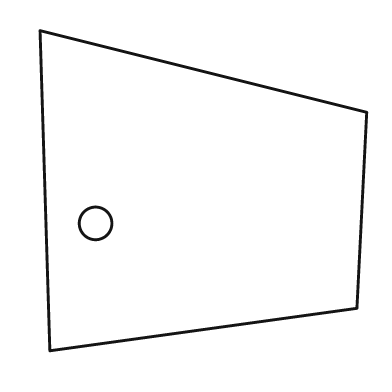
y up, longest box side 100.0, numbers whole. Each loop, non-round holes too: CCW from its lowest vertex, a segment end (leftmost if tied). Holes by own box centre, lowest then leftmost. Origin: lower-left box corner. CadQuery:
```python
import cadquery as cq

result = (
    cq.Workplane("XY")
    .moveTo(3.0, 0.0)
    .lineTo(97.0, 13.0)
    .lineTo(100.0, 73.0)
    .lineTo(0.0, 98.0)
    .close()
    .moveTo(17.0, 39.0)
    .circle(5.0)
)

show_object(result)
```